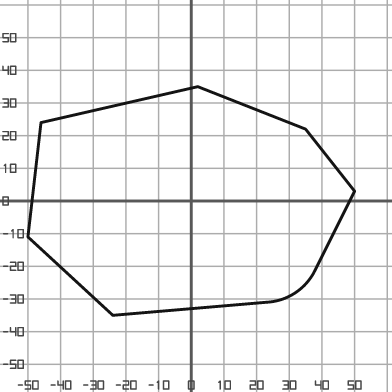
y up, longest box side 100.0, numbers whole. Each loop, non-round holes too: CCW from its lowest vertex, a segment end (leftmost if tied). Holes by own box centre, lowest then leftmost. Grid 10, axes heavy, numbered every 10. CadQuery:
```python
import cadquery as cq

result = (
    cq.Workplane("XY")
    .moveTo(-24.0, -35.0)
    .lineTo(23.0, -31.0)
    .threePointArc((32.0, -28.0), (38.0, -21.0))
    .lineTo(50.0, 3.0)
    .lineTo(35.0, 22.0)
    .lineTo(2.0, 35.0)
    .lineTo(-46.0, 24.0)
    .lineTo(-50.0, -11.0)
    .close()
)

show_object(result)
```